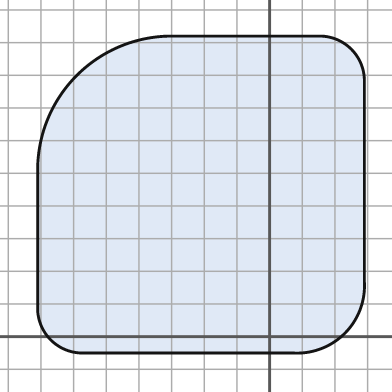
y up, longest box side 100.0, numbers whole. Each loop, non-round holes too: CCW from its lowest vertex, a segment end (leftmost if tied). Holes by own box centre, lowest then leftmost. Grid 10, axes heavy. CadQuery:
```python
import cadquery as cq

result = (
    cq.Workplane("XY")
    .moveTo(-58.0, -5.0)
    .lineTo(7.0, -5.0)
    .threePointArc((23.0, 1.0), (29.0, 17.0))
    .lineTo(29.0, 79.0)
    .threePointArc((25.0, 88.0), (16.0, 92.0))
    .lineTo(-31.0, 92.0)
    .threePointArc((-59.0, 80.0), (-71.0, 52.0))
    .lineTo(-71.0, 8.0)
    .threePointArc((-67.0, -1.0), (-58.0, -5.0))
    .close()
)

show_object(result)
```